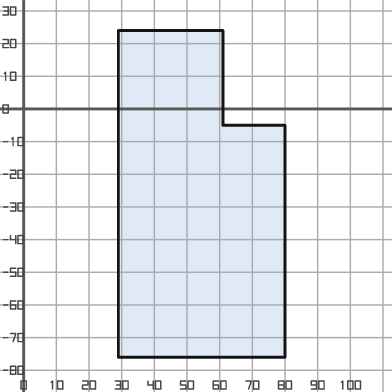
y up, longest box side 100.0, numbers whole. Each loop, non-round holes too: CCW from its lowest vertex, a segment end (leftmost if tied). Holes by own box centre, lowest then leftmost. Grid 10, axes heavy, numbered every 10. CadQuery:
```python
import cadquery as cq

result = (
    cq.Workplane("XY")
    .moveTo(29.0, -76.0)
    .lineTo(80.0, -76.0)
    .lineTo(80.0, -5.0)
    .lineTo(61.0, -5.0)
    .lineTo(61.0, 24.0)
    .lineTo(29.0, 24.0)
    .close()
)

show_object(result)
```